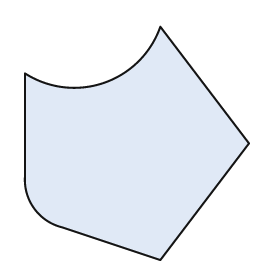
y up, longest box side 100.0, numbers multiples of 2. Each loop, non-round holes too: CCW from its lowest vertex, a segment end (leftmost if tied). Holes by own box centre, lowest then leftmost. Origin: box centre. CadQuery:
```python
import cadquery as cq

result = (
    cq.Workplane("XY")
    .moveTo(10.0, -50.0)
    .lineTo(48.0, 0.0)
    .lineTo(10.0, 50.0)
    .threePointArc((-14.0, 26.0), (-48.0, 30.0))
    .lineTo(-48.0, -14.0)
    .threePointArc((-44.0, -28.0), (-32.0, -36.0))
    .close()
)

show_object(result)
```